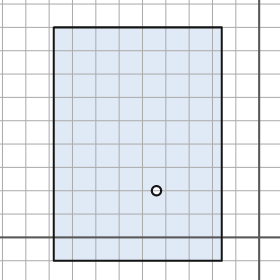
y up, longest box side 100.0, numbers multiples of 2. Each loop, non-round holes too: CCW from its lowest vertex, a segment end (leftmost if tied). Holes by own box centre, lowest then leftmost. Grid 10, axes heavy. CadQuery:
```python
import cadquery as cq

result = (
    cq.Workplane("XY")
    .moveTo(-88.0, -10.0)
    .lineTo(-16.0, -10.0)
    .lineTo(-16.0, 90.0)
    .lineTo(-88.0, 90.0)
    .close()
    .moveTo(-44.0, 20.0)
    .circle(2.0)
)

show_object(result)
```